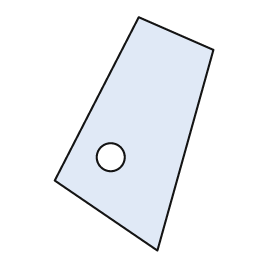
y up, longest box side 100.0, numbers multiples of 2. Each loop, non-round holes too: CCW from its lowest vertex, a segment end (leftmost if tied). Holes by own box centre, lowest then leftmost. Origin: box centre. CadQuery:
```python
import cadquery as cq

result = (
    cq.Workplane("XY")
    .moveTo(10.0, -50.0)
    .lineTo(34.0, 36.0)
    .lineTo(2.0, 50.0)
    .lineTo(-34.0, -20.0)
    .close()
    .moveTo(-10.0, -10.0)
    .circle(6.0)
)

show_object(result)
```